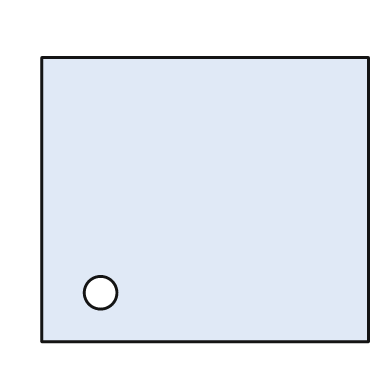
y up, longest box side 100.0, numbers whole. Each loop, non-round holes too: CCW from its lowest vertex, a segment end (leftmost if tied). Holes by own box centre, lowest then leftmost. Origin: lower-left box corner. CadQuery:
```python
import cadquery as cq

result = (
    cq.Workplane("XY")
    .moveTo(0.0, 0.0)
    .lineTo(100.0, 0.0)
    .lineTo(100.0, 87.0)
    .lineTo(0.0, 87.0)
    .close()
    .moveTo(18.0, 15.0)
    .circle(5.0)
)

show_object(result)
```